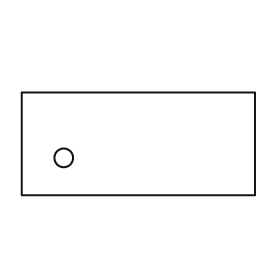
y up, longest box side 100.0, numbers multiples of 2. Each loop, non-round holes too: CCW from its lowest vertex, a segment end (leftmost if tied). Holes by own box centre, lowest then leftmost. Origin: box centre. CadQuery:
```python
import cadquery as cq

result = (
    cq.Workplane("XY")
    .moveTo(-50.0, -22.0)
    .lineTo(50.0, -22.0)
    .lineTo(50.0, 22.0)
    .lineTo(-50.0, 22.0)
    .close()
    .moveTo(-32.0, -6.0)
    .circle(4.0)
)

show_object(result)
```